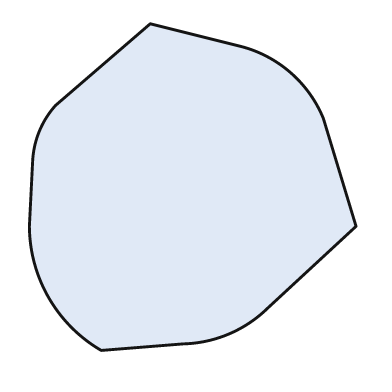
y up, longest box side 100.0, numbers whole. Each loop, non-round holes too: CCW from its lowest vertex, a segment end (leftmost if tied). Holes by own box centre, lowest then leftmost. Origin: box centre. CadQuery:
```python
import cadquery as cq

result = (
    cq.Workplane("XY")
    .moveTo(-28.0, -50.0)
    .lineTo(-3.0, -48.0)
    .threePointArc((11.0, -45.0), (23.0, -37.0))
    .lineTo(50.0, -12.0)
    .lineTo(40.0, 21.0)
    .threePointArc((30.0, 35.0), (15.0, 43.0))
    .lineTo(-13.0, 50.0)
    .lineTo(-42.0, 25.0)
    .threePointArc((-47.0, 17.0), (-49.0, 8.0))
    .lineTo(-50.0, -12.0)
    .threePointArc((-44.0, -34.0), (-28.0, -50.0))
    .close()
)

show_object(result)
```